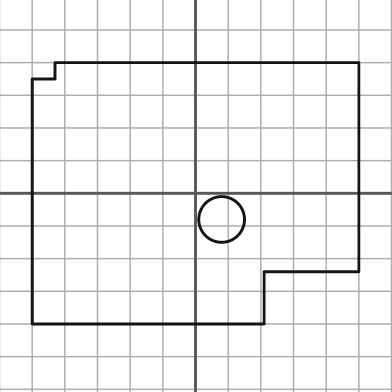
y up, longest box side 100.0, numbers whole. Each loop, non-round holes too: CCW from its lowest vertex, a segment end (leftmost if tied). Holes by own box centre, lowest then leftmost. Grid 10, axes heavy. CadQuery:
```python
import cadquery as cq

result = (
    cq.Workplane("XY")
    .moveTo(-50.0, -40.0)
    .lineTo(21.0, -40.0)
    .lineTo(21.0, -24.0)
    .lineTo(50.0, -24.0)
    .lineTo(50.0, 40.0)
    .lineTo(-43.0, 40.0)
    .lineTo(-43.0, 35.0)
    .lineTo(-50.0, 35.0)
    .close()
    .moveTo(8.0, -8.0)
    .circle(7.0)
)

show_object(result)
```